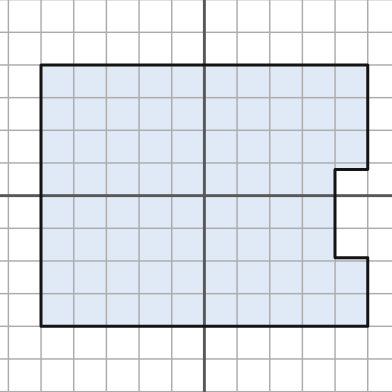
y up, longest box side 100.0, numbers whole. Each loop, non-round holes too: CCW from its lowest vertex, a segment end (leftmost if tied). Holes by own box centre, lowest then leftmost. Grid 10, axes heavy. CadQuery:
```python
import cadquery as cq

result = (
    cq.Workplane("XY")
    .moveTo(-50.0, -40.0)
    .lineTo(50.0, -40.0)
    .lineTo(50.0, -19.0)
    .lineTo(40.0, -19.0)
    .lineTo(40.0, 8.0)
    .lineTo(50.0, 8.0)
    .lineTo(50.0, 40.0)
    .lineTo(-50.0, 40.0)
    .close()
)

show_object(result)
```